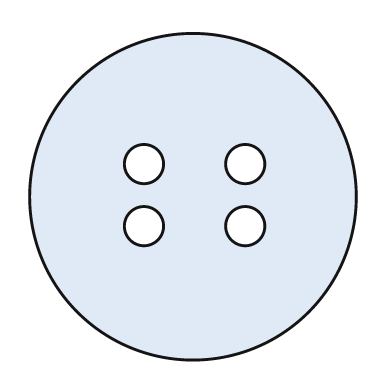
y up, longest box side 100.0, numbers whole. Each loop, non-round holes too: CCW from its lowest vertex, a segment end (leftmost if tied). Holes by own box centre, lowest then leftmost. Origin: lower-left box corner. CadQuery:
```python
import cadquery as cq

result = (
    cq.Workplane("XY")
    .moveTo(50.0, 50.0)
    .circle(50.0)
    .moveTo(35.0, 41.0)
    .circle(6.0)
    .moveTo(66.0, 41.0)
    .circle(6.0)
    .moveTo(35.0, 60.0)
    .circle(6.0)
    .moveTo(66.0, 60.0)
    .circle(6.0)
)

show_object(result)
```